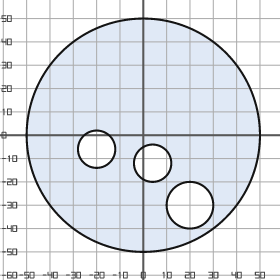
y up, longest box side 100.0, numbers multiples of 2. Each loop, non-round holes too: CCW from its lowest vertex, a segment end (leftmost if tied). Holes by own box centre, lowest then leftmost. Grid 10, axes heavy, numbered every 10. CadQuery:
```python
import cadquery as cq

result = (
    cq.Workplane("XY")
    .moveTo(0.0, 0.0)
    .circle(50.0)
    .moveTo(20.0, -30.0)
    .circle(10.0)
    .moveTo(4.0, -12.0)
    .circle(8.0)
    .moveTo(-20.0, -6.0)
    .circle(8.0)
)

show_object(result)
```